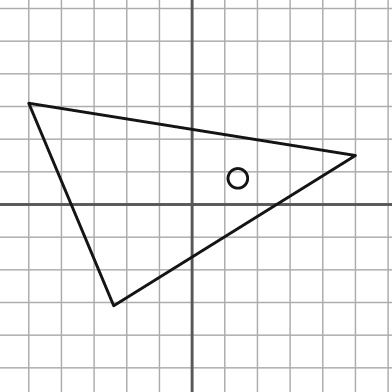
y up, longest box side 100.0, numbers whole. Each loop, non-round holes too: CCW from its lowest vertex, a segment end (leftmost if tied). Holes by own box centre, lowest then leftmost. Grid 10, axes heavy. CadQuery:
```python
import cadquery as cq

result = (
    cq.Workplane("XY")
    .moveTo(-24.0, -31.0)
    .lineTo(50.0, 15.0)
    .lineTo(-50.0, 31.0)
    .close()
    .moveTo(14.0, 8.0)
    .circle(3.0)
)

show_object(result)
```